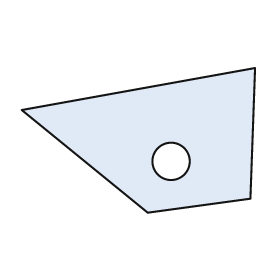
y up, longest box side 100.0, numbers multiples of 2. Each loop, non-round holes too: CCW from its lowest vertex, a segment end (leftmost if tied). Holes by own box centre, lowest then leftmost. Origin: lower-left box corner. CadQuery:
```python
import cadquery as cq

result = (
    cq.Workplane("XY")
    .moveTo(54.0, 0.0)
    .lineTo(98.0, 6.0)
    .lineTo(100.0, 62.0)
    .lineTo(0.0, 44.0)
    .close()
    .moveTo(64.0, 22.0)
    .circle(8.0)
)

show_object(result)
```